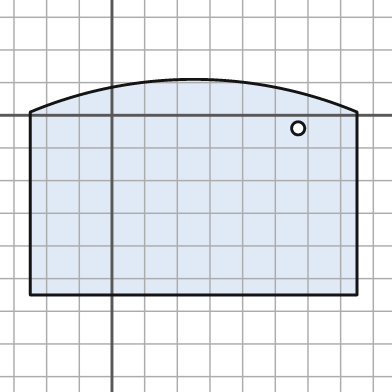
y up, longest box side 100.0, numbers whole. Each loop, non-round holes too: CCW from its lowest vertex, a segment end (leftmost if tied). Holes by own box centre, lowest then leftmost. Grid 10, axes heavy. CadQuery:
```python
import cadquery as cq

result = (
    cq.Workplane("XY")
    .moveTo(-25.0, -55.0)
    .lineTo(75.0, -55.0)
    .lineTo(75.0, 1.0)
    .threePointArc((25.0, 11.0), (-25.0, 1.0))
    .close()
    .moveTo(57.0, -4.0)
    .circle(2.0)
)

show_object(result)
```